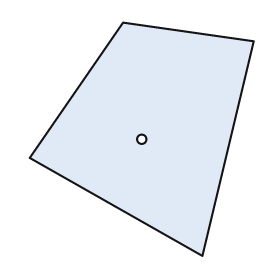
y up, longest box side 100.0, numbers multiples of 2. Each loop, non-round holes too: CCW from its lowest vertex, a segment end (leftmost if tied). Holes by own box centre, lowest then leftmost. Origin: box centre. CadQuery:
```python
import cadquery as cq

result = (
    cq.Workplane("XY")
    .moveTo(26.0, -50.0)
    .lineTo(48.0, 42.0)
    .lineTo(-8.0, 50.0)
    .lineTo(-48.0, -8.0)
    .close()
    .moveTo(0.0, 0.0)
    .circle(2.0)
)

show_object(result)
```